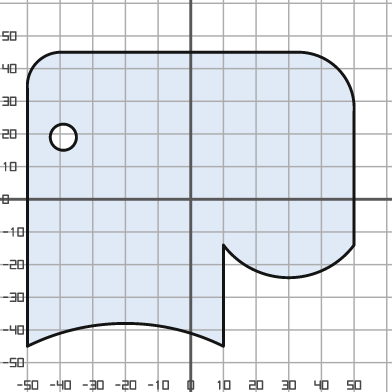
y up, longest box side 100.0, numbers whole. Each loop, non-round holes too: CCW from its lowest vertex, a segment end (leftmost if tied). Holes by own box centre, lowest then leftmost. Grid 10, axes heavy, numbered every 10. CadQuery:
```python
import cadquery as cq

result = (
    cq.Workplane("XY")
    .moveTo(-50.0, -45.0)
    .threePointArc((-20.0, -38.0), (10.0, -45.0))
    .lineTo(10.0, -14.0)
    .threePointArc((30.0, -24.0), (50.0, -14.0))
    .lineTo(50.0, 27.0)
    .threePointArc((45.0, 40.0), (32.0, 45.0))
    .lineTo(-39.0, 45.0)
    .threePointArc((-47.0, 42.0), (-50.0, 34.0))
    .close()
    .moveTo(-39.0, 19.0)
    .circle(4.0)
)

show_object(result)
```